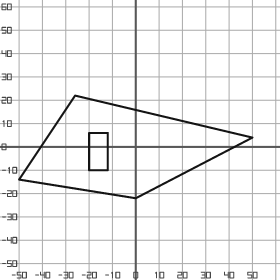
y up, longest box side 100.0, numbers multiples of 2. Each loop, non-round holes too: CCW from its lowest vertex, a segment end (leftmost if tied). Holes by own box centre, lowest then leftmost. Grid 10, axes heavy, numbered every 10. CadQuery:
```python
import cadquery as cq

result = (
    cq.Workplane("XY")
    .moveTo(0.0, -22.0)
    .lineTo(50.0, 4.0)
    .lineTo(-26.0, 22.0)
    .lineTo(-50.0, -14.0)
    .close()
    .moveTo(-20.0, -10.0)
    .lineTo(-12.0, -10.0)
    .lineTo(-12.0, 6.0)
    .lineTo(-20.0, 6.0)
    .close()
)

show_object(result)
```